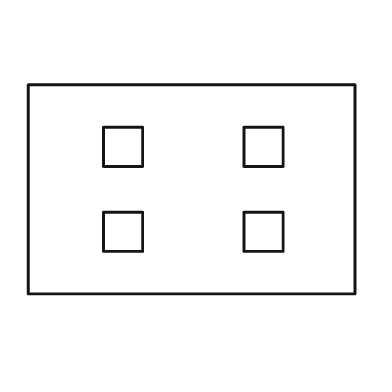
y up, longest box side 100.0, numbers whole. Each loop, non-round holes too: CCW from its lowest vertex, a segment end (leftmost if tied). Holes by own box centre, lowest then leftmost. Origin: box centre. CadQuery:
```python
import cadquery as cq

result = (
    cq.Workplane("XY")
    .moveTo(-50.0, -32.0)
    .lineTo(50.0, -32.0)
    .lineTo(50.0, 32.0)
    .lineTo(-50.0, 32.0)
    .close()
    .moveTo(-27.0, -19.0)
    .lineTo(-15.0, -19.0)
    .lineTo(-15.0, -7.0)
    .lineTo(-27.0, -7.0)
    .close()
    .moveTo(16.0, -19.0)
    .lineTo(28.0, -19.0)
    .lineTo(28.0, -7.0)
    .lineTo(16.0, -7.0)
    .close()
    .moveTo(-27.0, 7.0)
    .lineTo(-15.0, 7.0)
    .lineTo(-15.0, 19.0)
    .lineTo(-27.0, 19.0)
    .close()
    .moveTo(16.0, 7.0)
    .lineTo(28.0, 7.0)
    .lineTo(28.0, 19.0)
    .lineTo(16.0, 19.0)
    .close()
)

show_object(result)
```